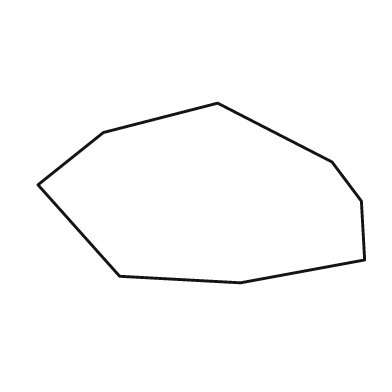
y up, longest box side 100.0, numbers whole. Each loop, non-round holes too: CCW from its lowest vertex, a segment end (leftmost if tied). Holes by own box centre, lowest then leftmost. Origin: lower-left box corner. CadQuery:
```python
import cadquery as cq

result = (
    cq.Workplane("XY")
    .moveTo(62.0, 0.0)
    .lineTo(100.0, 7.0)
    .lineTo(99.0, 25.0)
    .lineTo(90.0, 37.0)
    .lineTo(55.0, 55.0)
    .lineTo(20.0, 46.0)
    .lineTo(0.0, 30.0)
    .lineTo(25.0, 2.0)
    .close()
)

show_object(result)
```